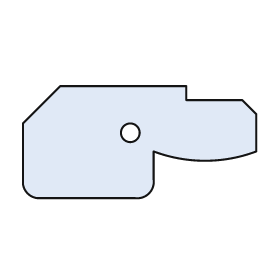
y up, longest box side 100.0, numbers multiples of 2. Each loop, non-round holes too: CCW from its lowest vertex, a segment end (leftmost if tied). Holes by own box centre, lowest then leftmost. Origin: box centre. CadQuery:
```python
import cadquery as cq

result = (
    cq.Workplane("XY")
    .moveTo(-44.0, -24.0)
    .lineTo(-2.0, -24.0)
    .threePointArc((4.0, -22.0), (6.0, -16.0))
    .lineTo(6.0, -4.0)
    .threePointArc((28.0, -8.0), (50.0, -4.0))
    .lineTo(50.0, 12.0)
    .lineTo(44.0, 18.0)
    .lineTo(20.0, 18.0)
    .lineTo(20.0, 24.0)
    .lineTo(-34.0, 24.0)
    .lineTo(-50.0, 8.0)
    .lineTo(-50.0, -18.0)
    .threePointArc((-48.0, -22.0), (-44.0, -24.0))
    .close()
    .moveTo(-4.0, 4.0)
    .circle(4.0)
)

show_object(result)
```